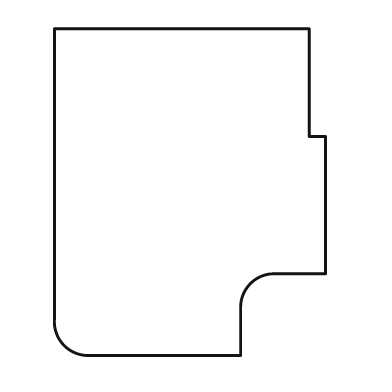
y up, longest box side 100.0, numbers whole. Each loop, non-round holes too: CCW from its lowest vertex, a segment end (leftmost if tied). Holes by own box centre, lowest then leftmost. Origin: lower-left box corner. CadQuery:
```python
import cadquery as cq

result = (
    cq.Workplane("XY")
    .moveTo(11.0, 0.0)
    .lineTo(57.0, 0.0)
    .lineTo(57.0, 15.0)
    .threePointArc((60.0, 22.0), (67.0, 25.0))
    .lineTo(83.0, 25.0)
    .lineTo(83.0, 67.0)
    .lineTo(78.0, 67.0)
    .lineTo(78.0, 100.0)
    .lineTo(0.0, 100.0)
    .lineTo(0.0, 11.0)
    .threePointArc((3.0, 3.0), (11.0, 0.0))
    .close()
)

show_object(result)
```